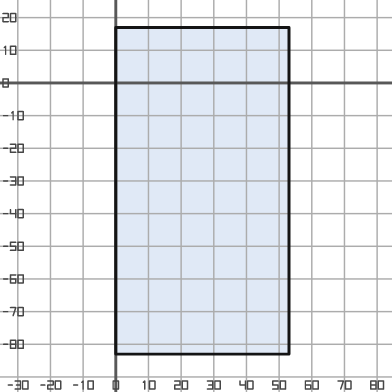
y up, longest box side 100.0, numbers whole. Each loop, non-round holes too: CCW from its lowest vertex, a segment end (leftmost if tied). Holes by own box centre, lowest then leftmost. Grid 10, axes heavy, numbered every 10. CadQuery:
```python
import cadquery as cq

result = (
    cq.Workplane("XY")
    .moveTo(0.0, -83.0)
    .lineTo(53.0, -83.0)
    .lineTo(53.0, 17.0)
    .lineTo(0.0, 17.0)
    .close()
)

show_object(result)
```